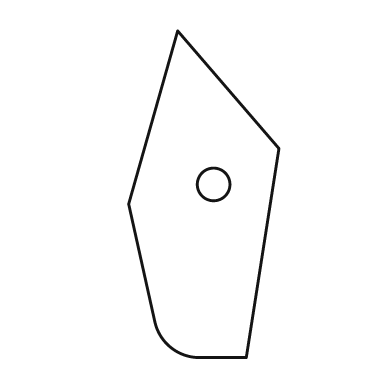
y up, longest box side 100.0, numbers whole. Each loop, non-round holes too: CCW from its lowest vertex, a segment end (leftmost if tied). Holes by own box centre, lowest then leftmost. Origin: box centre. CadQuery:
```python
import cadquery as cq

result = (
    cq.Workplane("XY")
    .moveTo(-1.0, -50.0)
    .lineTo(13.0, -50.0)
    .lineTo(23.0, 14.0)
    .lineTo(-8.0, 50.0)
    .lineTo(-23.0, -3.0)
    .lineTo(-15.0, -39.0)
    .threePointArc((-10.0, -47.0), (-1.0, -50.0))
    .close()
    .moveTo(3.0, 3.0)
    .circle(5.0)
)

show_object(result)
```